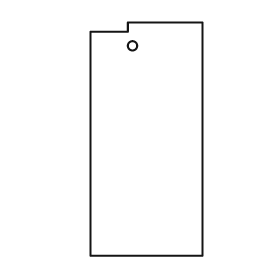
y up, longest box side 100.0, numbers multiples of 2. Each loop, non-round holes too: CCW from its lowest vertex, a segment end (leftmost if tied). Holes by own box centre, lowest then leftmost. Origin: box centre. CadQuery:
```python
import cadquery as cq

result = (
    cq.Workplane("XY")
    .moveTo(-24.0, -50.0)
    .lineTo(24.0, -50.0)
    .lineTo(24.0, 50.0)
    .lineTo(-8.0, 50.0)
    .lineTo(-8.0, 46.0)
    .lineTo(-24.0, 46.0)
    .close()
    .moveTo(-6.0, 40.0)
    .circle(2.0)
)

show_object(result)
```